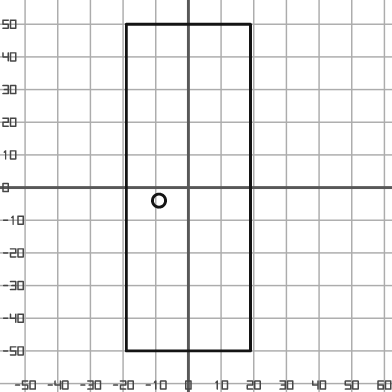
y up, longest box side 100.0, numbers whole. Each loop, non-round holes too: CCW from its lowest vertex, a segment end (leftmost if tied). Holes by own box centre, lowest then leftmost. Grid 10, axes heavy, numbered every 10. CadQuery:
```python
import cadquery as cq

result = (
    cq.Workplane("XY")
    .moveTo(-19.0, -50.0)
    .lineTo(19.0, -50.0)
    .lineTo(19.0, 50.0)
    .lineTo(-19.0, 50.0)
    .close()
    .moveTo(-9.0, -4.0)
    .circle(2.0)
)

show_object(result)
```